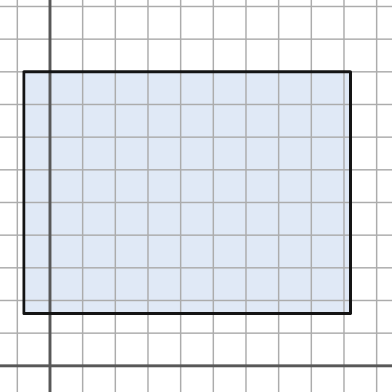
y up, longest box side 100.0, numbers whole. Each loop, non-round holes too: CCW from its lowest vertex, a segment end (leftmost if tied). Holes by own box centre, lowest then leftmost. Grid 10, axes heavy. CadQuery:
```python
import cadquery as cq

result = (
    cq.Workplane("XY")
    .moveTo(-8.0, 16.0)
    .lineTo(92.0, 16.0)
    .lineTo(92.0, 90.0)
    .lineTo(-8.0, 90.0)
    .close()
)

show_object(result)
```